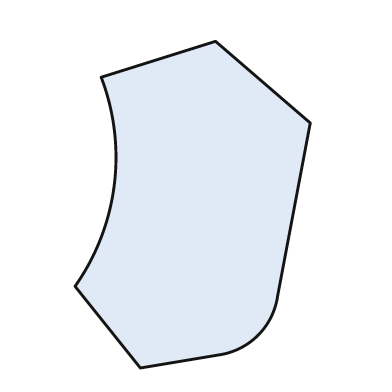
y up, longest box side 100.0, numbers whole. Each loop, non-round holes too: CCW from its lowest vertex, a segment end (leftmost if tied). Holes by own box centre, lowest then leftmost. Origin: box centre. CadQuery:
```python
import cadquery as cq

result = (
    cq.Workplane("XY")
    .moveTo(-16.0, -50.0)
    .lineTo(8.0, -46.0)
    .threePointArc((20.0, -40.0), (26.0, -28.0))
    .lineTo(36.0, 25.0)
    .lineTo(7.0, 50.0)
    .lineTo(-28.0, 39.0)
    .threePointArc((-24.0, 6.0), (-36.0, -25.0))
    .close()
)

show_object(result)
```